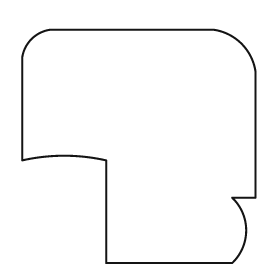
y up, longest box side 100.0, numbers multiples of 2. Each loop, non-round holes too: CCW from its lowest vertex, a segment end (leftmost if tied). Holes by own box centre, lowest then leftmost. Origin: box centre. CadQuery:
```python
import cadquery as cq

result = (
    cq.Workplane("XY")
    .moveTo(-14.0, -50.0)
    .lineTo(40.0, -50.0)
    .threePointArc((46.0, -36.0), (40.0, -22.0))
    .lineTo(50.0, -22.0)
    .lineTo(50.0, 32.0)
    .threePointArc((44.0, 44.0), (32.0, 50.0))
    .lineTo(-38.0, 50.0)
    .threePointArc((-46.0, 46.0), (-50.0, 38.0))
    .lineTo(-50.0, -6.0)
    .threePointArc((-32.0, -4.0), (-14.0, -6.0))
    .close()
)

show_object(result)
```